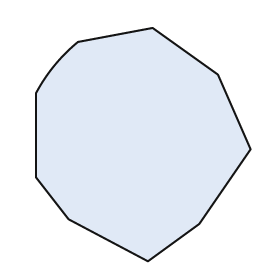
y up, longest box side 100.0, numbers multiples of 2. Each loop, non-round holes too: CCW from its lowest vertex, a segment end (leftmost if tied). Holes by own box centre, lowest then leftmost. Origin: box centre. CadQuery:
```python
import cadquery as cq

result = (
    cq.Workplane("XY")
    .moveTo(2.0, -50.0)
    .lineTo(24.0, -34.0)
    .lineTo(46.0, -2.0)
    .lineTo(32.0, 30.0)
    .lineTo(4.0, 50.0)
    .lineTo(-28.0, 44.0)
    .threePointArc((-38.0, 34.0), (-46.0, 22.0))
    .lineTo(-46.0, -14.0)
    .lineTo(-32.0, -32.0)
    .close()
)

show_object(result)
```